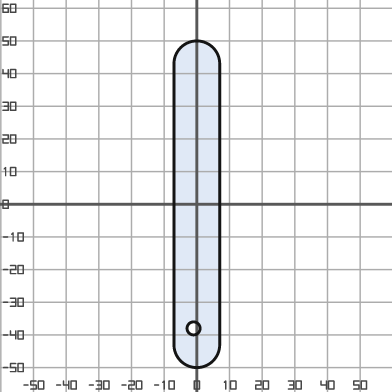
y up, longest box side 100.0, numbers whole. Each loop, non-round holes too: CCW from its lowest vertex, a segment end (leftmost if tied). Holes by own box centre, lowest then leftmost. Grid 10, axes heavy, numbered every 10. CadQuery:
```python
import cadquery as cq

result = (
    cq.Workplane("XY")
    .moveTo(-7.0, -43.0)
    .threePointArc((0.0, -50.0), (7.0, -43.0))
    .lineTo(7.0, 43.0)
    .threePointArc((0.0, 50.0), (-7.0, 43.0))
    .close()
    .moveTo(-1.0, -38.0)
    .circle(2.0)
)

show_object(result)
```